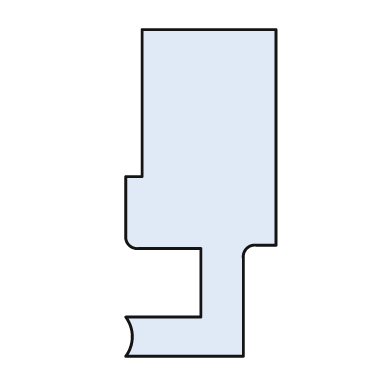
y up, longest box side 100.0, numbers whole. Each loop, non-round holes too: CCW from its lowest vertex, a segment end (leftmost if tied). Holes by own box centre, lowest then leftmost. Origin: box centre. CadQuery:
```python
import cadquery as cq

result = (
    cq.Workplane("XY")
    .moveTo(-23.0, -50.0)
    .lineTo(13.0, -50.0)
    .lineTo(13.0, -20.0)
    .threePointArc((14.0, -17.0), (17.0, -16.0))
    .lineTo(23.0, -16.0)
    .lineTo(23.0, 50.0)
    .lineTo(-18.0, 50.0)
    .lineTo(-18.0, 5.0)
    .lineTo(-23.0, 5.0)
    .lineTo(-23.0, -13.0)
    .threePointArc((-22.0, -16.0), (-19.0, -17.0))
    .lineTo(0.0, -17.0)
    .lineTo(0.0, -38.0)
    .lineTo(-23.0, -38.0)
    .threePointArc((-21.0, -44.0), (-23.0, -50.0))
    .close()
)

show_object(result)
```